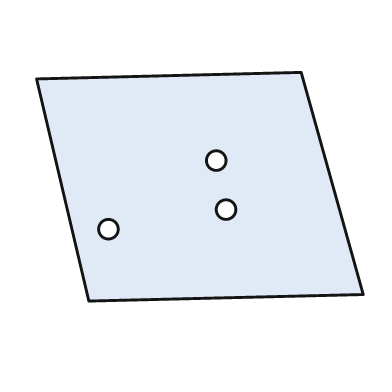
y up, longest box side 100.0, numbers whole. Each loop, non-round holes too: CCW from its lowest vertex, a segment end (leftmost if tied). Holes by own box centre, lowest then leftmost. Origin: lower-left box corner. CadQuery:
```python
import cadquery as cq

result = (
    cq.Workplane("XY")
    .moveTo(16.0, 0.0)
    .lineTo(100.0, 2.0)
    .lineTo(81.0, 70.0)
    .lineTo(0.0, 68.0)
    .close()
    .moveTo(22.0, 22.0)
    .circle(3.0)
    .moveTo(58.0, 28.0)
    .circle(3.0)
    .moveTo(55.0, 43.0)
    .circle(3.0)
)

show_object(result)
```